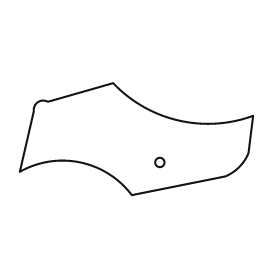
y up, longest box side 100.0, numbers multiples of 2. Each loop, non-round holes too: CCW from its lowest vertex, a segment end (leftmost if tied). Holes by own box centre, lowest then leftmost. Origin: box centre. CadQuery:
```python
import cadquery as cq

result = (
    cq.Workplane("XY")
    .moveTo(-2.0, -24.0)
    .lineTo(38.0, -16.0)
    .threePointArc((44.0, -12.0), (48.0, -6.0))
    .lineTo(50.0, 10.0)
    .threePointArc((18.0, 8.0), (-10.0, 24.0))
    .lineTo(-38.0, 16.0)
    .threePointArc((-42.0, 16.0), (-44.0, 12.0))
    .lineTo(-50.0, -14.0)
    .threePointArc((-24.0, -10.0), (-2.0, -24.0))
    .close()
    .moveTo(10.0, -10.0)
    .circle(2.0)
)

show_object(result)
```